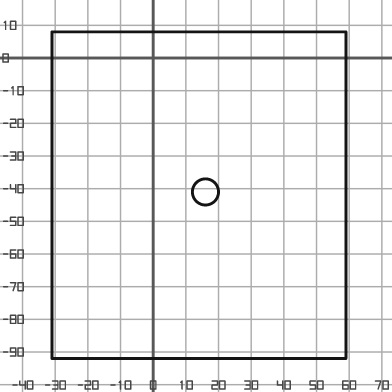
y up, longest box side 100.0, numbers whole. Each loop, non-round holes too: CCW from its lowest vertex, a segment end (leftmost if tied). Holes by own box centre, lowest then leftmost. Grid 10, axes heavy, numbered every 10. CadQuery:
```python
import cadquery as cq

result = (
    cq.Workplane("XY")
    .moveTo(-31.0, -92.0)
    .lineTo(59.0, -92.0)
    .lineTo(59.0, 8.0)
    .lineTo(-31.0, 8.0)
    .close()
    .moveTo(16.0, -41.0)
    .circle(4.0)
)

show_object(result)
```